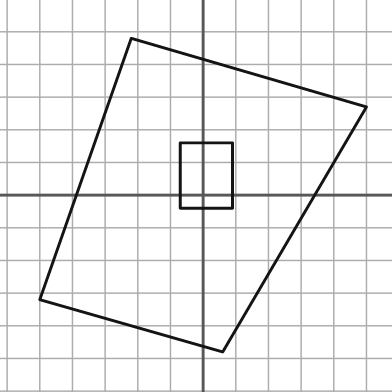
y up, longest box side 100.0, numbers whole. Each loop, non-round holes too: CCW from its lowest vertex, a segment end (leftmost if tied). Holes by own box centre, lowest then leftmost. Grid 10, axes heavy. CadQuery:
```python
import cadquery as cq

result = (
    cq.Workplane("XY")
    .moveTo(6.0, -48.0)
    .lineTo(50.0, 27.0)
    .lineTo(-22.0, 48.0)
    .lineTo(-50.0, -32.0)
    .close()
    .moveTo(-7.0, -4.0)
    .lineTo(9.0, -4.0)
    .lineTo(9.0, 16.0)
    .lineTo(-7.0, 16.0)
    .close()
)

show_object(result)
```